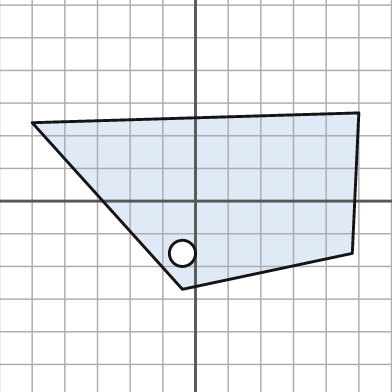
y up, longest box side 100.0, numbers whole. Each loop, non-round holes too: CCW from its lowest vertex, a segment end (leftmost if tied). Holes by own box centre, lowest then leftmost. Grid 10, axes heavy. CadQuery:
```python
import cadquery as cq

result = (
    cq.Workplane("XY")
    .moveTo(-4.0, -27.0)
    .lineTo(48.0, -16.0)
    .lineTo(50.0, 27.0)
    .lineTo(-50.0, 24.0)
    .close()
    .moveTo(-4.0, -16.0)
    .circle(4.0)
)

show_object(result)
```